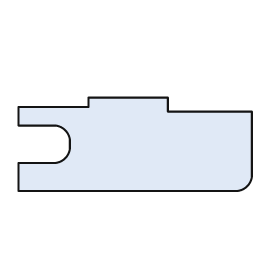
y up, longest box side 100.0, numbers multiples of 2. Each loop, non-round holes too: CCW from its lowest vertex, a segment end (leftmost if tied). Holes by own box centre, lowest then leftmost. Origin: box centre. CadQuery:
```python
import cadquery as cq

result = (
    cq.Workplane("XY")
    .moveTo(-50.0, -20.0)
    .lineTo(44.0, -20.0)
    .threePointArc((48.0, -18.0), (50.0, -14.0))
    .lineTo(50.0, 14.0)
    .lineTo(14.0, 14.0)
    .lineTo(14.0, 20.0)
    .lineTo(-20.0, 20.0)
    .lineTo(-20.0, 16.0)
    .lineTo(-50.0, 16.0)
    .lineTo(-50.0, 8.0)
    .lineTo(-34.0, 8.0)
    .threePointArc((-30.0, 6.0), (-28.0, 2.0))
    .lineTo(-28.0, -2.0)
    .threePointArc((-30.0, -6.0), (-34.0, -8.0))
    .lineTo(-50.0, -8.0)
    .close()
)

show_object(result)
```